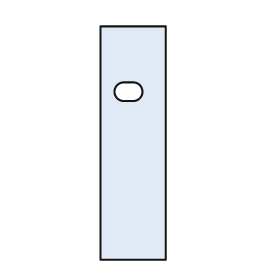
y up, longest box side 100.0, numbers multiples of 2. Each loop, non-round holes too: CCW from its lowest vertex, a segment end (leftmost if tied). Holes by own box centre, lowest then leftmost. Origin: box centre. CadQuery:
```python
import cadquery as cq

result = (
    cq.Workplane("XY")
    .moveTo(-14.0, -50.0)
    .lineTo(14.0, -50.0)
    .lineTo(14.0, 50.0)
    .lineTo(-14.0, 50.0)
    .close()
    .moveTo(-4.0, 18.0)
    .lineTo(0.0, 18.0)
    .threePointArc((4.0, 22.0), (0.0, 26.0))
    .lineTo(-4.0, 26.0)
    .threePointArc((-8.0, 22.0), (-4.0, 18.0))
    .close()
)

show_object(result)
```